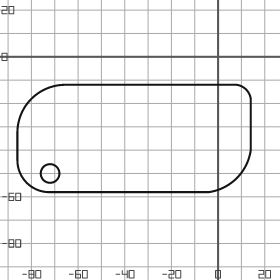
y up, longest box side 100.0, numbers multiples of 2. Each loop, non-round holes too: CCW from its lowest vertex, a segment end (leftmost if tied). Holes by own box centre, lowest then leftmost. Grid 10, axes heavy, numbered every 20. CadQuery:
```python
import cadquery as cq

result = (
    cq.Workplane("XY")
    .moveTo(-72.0, -58.0)
    .lineTo(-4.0, -58.0)
    .threePointArc((8.0, -52.0), (14.0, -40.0))
    .lineTo(14.0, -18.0)
    .threePointArc((12.0, -14.0), (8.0, -12.0))
    .lineTo(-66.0, -12.0)
    .threePointArc((-80.0, -18.0), (-86.0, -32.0))
    .lineTo(-86.0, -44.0)
    .threePointArc((-82.0, -54.0), (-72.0, -58.0))
    .close()
    .moveTo(-72.0, -50.0)
    .circle(4.0)
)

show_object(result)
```